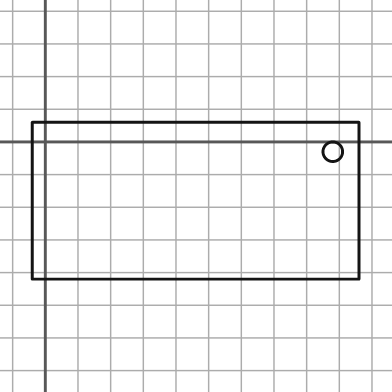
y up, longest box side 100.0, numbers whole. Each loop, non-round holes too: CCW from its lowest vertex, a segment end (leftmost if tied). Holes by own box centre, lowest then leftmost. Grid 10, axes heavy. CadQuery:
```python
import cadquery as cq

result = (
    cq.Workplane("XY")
    .moveTo(-4.0, -42.0)
    .lineTo(96.0, -42.0)
    .lineTo(96.0, 6.0)
    .lineTo(-4.0, 6.0)
    .close()
    .moveTo(88.0, -3.0)
    .circle(3.0)
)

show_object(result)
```